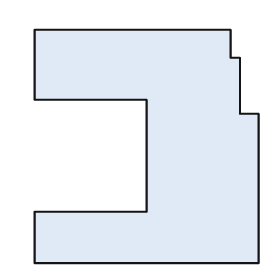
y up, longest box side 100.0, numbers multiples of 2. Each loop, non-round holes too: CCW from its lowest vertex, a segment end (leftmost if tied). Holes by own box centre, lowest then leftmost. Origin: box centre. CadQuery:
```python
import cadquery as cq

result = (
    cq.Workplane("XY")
    .moveTo(-48.0, -50.0)
    .lineTo(48.0, -50.0)
    .lineTo(48.0, 14.0)
    .lineTo(40.0, 14.0)
    .lineTo(40.0, 38.0)
    .lineTo(36.0, 38.0)
    .lineTo(36.0, 50.0)
    .lineTo(-48.0, 50.0)
    .lineTo(-48.0, 20.0)
    .lineTo(0.0, 20.0)
    .lineTo(0.0, -28.0)
    .lineTo(-48.0, -28.0)
    .close()
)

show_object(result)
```